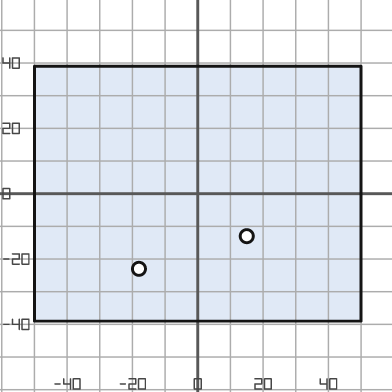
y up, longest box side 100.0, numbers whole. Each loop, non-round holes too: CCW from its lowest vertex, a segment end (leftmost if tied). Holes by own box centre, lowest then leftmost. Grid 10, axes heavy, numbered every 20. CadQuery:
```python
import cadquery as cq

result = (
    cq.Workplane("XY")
    .moveTo(-50.0, -39.0)
    .lineTo(50.0, -39.0)
    .lineTo(50.0, 39.0)
    .lineTo(-50.0, 39.0)
    .close()
    .moveTo(-18.0, -23.0)
    .circle(2.0)
    .moveTo(15.0, -13.0)
    .circle(2.0)
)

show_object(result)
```